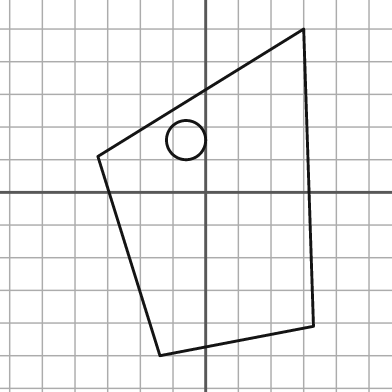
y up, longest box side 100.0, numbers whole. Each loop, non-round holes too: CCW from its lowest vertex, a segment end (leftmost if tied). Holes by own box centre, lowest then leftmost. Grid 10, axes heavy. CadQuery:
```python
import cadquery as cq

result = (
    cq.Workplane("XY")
    .moveTo(-14.0, -50.0)
    .lineTo(33.0, -41.0)
    .lineTo(30.0, 50.0)
    .lineTo(-33.0, 11.0)
    .close()
    .moveTo(-6.0, 16.0)
    .circle(6.0)
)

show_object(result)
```